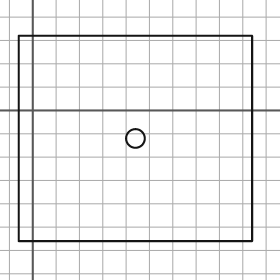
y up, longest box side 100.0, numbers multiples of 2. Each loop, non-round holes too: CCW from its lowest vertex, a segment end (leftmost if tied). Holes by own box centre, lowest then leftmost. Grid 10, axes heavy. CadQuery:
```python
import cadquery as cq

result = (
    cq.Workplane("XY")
    .moveTo(-6.0, -56.0)
    .lineTo(94.0, -56.0)
    .lineTo(94.0, 32.0)
    .lineTo(-6.0, 32.0)
    .close()
    .moveTo(44.0, -12.0)
    .circle(4.0)
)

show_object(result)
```